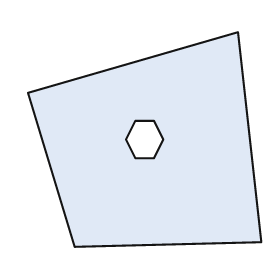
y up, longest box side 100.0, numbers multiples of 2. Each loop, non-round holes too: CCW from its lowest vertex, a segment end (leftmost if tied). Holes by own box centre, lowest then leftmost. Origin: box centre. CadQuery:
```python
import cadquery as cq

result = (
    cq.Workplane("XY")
    .moveTo(-30.0, -46.0)
    .lineTo(50.0, -44.0)
    .lineTo(40.0, 46.0)
    .lineTo(-50.0, 20.0)
    .close()
    .moveTo(-4.0, -8.0)
    .lineTo(4.0, -8.0)
    .lineTo(8.0, 0.0)
    .lineTo(4.0, 8.0)
    .lineTo(-4.0, 8.0)
    .lineTo(-8.0, 0.0)
    .close()
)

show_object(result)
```